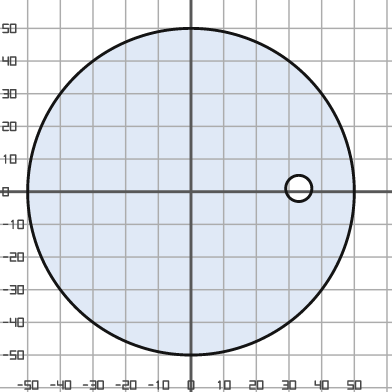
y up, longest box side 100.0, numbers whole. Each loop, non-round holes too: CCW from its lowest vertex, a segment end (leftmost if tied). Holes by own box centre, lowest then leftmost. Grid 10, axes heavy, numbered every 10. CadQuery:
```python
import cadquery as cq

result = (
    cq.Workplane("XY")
    .moveTo(0.0, 0.0)
    .circle(50.0)
    .moveTo(33.0, 1.0)
    .circle(4.0)
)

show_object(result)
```